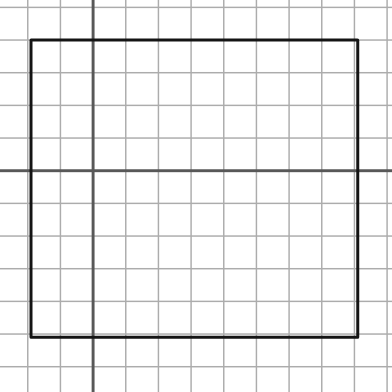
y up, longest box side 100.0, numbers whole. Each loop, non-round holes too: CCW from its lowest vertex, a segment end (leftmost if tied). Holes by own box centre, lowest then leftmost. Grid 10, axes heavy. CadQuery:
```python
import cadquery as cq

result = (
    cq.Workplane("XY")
    .moveTo(-19.0, -51.0)
    .lineTo(81.0, -51.0)
    .lineTo(81.0, 40.0)
    .lineTo(-19.0, 40.0)
    .close()
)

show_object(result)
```